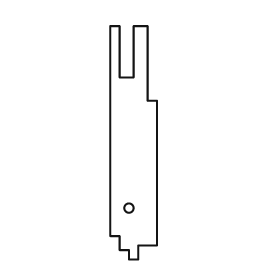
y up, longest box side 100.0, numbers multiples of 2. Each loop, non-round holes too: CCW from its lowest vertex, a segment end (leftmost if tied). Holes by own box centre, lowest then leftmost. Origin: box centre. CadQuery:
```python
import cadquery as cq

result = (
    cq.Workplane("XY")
    .moveTo(-2.0, -50.0)
    .lineTo(2.0, -50.0)
    .lineTo(2.0, -44.0)
    .lineTo(10.0, -44.0)
    .lineTo(10.0, 18.0)
    .lineTo(6.0, 18.0)
    .lineTo(6.0, 50.0)
    .lineTo(0.0, 50.0)
    .lineTo(0.0, 28.0)
    .lineTo(-6.0, 28.0)
    .lineTo(-6.0, 50.0)
    .lineTo(-10.0, 50.0)
    .lineTo(-10.0, -40.0)
    .lineTo(-6.0, -40.0)
    .lineTo(-6.0, -46.0)
    .lineTo(-2.0, -46.0)
    .close()
    .moveTo(-2.0, -28.0)
    .circle(2.0)
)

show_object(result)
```